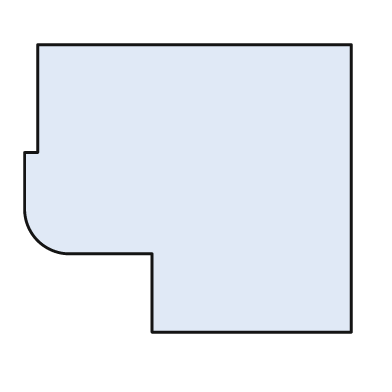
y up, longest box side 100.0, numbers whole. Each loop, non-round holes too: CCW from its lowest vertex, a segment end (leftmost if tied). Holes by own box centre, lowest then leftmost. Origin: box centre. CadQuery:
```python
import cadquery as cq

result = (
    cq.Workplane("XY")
    .moveTo(-11.0, -44.0)
    .lineTo(50.0, -44.0)
    .lineTo(50.0, 44.0)
    .lineTo(-46.0, 44.0)
    .lineTo(-46.0, 11.0)
    .lineTo(-50.0, 11.0)
    .lineTo(-50.0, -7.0)
    .threePointArc((-46.0, -16.0), (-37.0, -20.0))
    .lineTo(-11.0, -20.0)
    .close()
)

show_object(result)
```